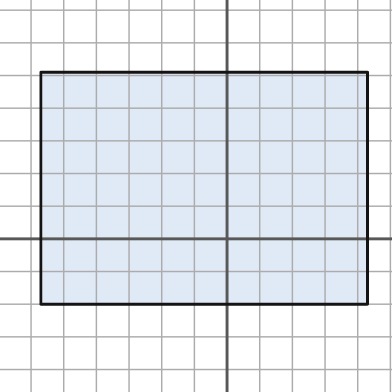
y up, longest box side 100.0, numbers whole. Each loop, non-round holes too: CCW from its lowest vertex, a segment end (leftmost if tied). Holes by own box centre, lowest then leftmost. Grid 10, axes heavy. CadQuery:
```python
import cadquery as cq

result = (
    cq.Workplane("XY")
    .moveTo(-57.0, -20.0)
    .lineTo(43.0, -20.0)
    .lineTo(43.0, 51.0)
    .lineTo(-57.0, 51.0)
    .close()
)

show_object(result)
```